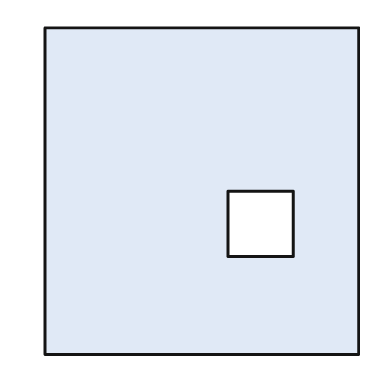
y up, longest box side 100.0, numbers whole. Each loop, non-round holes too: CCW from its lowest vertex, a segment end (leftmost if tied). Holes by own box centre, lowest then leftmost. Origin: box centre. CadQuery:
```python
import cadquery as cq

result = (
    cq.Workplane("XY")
    .moveTo(-48.0, -50.0)
    .lineTo(48.0, -50.0)
    .lineTo(48.0, 50.0)
    .lineTo(-48.0, 50.0)
    .close()
    .moveTo(8.0, -20.0)
    .lineTo(28.0, -20.0)
    .lineTo(28.0, 0.0)
    .lineTo(8.0, 0.0)
    .close()
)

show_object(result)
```